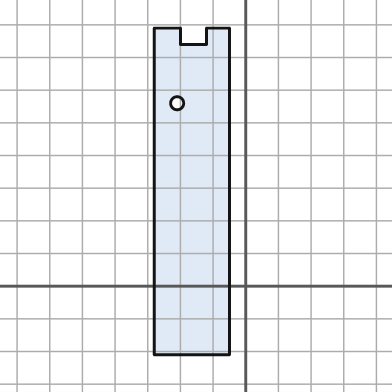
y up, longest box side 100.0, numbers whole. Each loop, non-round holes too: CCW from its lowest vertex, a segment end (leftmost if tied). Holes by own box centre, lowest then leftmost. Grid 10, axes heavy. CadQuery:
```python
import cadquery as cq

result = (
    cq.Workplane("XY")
    .moveTo(-28.0, -21.0)
    .lineTo(-5.0, -21.0)
    .lineTo(-5.0, 79.0)
    .lineTo(-12.0, 79.0)
    .lineTo(-12.0, 74.0)
    .lineTo(-20.0, 74.0)
    .lineTo(-20.0, 79.0)
    .lineTo(-28.0, 79.0)
    .close()
    .moveTo(-21.0, 56.0)
    .circle(2.0)
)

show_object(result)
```